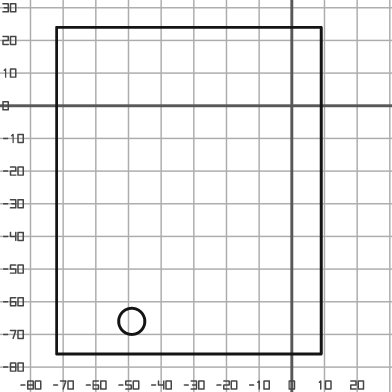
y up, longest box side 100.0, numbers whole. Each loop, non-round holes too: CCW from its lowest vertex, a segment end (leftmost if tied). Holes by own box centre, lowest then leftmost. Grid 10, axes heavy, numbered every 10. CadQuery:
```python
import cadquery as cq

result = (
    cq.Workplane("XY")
    .moveTo(-72.0, -76.0)
    .lineTo(9.0, -76.0)
    .lineTo(9.0, 24.0)
    .lineTo(-72.0, 24.0)
    .close()
    .moveTo(-49.0, -66.0)
    .circle(4.0)
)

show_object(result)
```